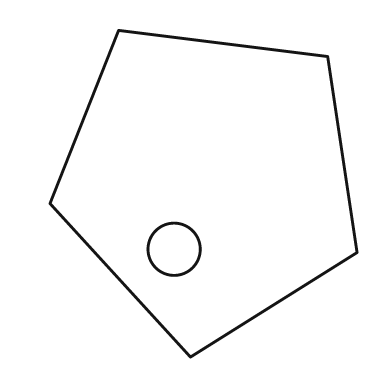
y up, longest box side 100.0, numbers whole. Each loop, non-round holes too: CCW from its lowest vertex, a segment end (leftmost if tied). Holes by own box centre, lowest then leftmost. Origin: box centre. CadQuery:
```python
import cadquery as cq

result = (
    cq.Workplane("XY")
    .moveTo(-4.0, -50.0)
    .lineTo(47.0, -18.0)
    .lineTo(38.0, 42.0)
    .lineTo(-26.0, 50.0)
    .lineTo(-47.0, -3.0)
    .close()
    .moveTo(-9.0, -17.0)
    .circle(8.0)
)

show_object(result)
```